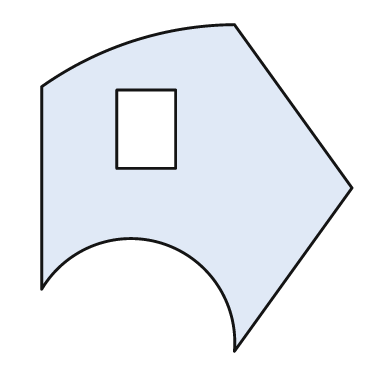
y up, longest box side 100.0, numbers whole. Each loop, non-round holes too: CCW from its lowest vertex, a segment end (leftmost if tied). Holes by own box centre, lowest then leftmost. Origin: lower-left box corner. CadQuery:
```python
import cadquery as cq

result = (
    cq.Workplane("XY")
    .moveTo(59.0, 0.0)
    .lineTo(95.0, 50.0)
    .lineTo(59.0, 100.0)
    .threePointArc((28.0, 95.0), (0.0, 81.0))
    .lineTo(0.0, 19.0)
    .threePointArc((37.0, 33.0), (59.0, 0.0))
    .close()
    .moveTo(23.0, 56.0)
    .lineTo(41.0, 56.0)
    .lineTo(41.0, 80.0)
    .lineTo(23.0, 80.0)
    .close()
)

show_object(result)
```